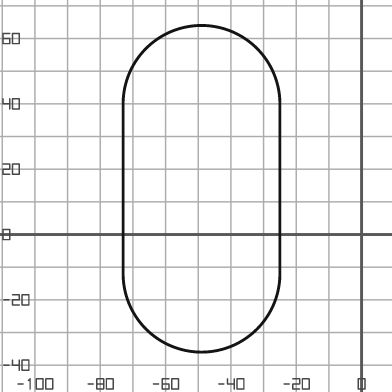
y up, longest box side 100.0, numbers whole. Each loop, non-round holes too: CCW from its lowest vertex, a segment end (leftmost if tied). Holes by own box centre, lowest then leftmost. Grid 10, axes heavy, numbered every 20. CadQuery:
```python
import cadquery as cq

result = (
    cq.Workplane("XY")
    .moveTo(-73.0, -12.0)
    .threePointArc((-49.0, -36.0), (-25.0, -12.0))
    .lineTo(-25.0, 40.0)
    .threePointArc((-49.0, 64.0), (-73.0, 40.0))
    .close()
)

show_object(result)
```